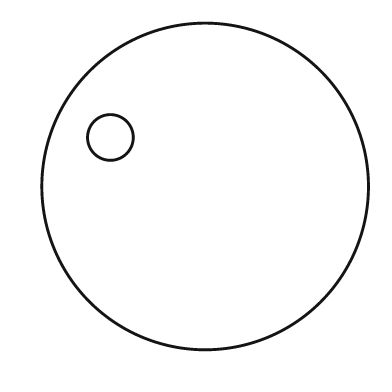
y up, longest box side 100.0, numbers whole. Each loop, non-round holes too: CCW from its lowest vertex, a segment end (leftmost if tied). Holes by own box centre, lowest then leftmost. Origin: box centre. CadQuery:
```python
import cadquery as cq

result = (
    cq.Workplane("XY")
    .moveTo(0.0, 0.0)
    .circle(50.0)
    .moveTo(-29.0, 15.0)
    .circle(7.0)
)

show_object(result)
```